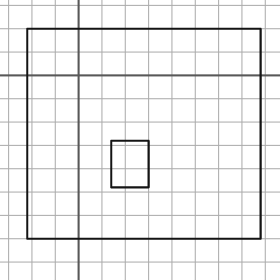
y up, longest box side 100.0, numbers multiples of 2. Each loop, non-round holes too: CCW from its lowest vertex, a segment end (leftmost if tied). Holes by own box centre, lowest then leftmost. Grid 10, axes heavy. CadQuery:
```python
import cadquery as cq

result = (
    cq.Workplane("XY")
    .moveTo(-22.0, -70.0)
    .lineTo(78.0, -70.0)
    .lineTo(78.0, 20.0)
    .lineTo(-22.0, 20.0)
    .close()
    .moveTo(14.0, -48.0)
    .lineTo(30.0, -48.0)
    .lineTo(30.0, -28.0)
    .lineTo(14.0, -28.0)
    .close()
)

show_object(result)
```